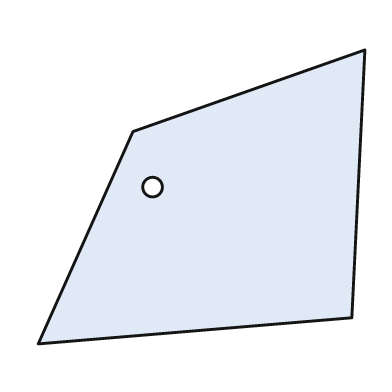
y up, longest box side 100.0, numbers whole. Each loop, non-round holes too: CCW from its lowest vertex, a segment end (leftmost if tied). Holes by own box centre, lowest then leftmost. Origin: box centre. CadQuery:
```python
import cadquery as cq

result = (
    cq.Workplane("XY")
    .moveTo(-50.0, -45.0)
    .lineTo(46.0, -37.0)
    .lineTo(50.0, 45.0)
    .lineTo(-21.0, 20.0)
    .close()
    .moveTo(-15.0, 3.0)
    .circle(3.0)
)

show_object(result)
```